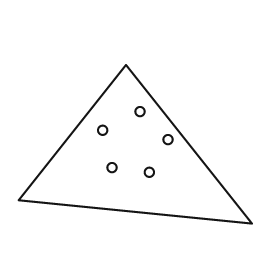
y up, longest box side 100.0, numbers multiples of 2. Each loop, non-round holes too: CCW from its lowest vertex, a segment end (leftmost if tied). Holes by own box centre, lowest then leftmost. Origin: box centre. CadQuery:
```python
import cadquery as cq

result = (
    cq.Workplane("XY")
    .moveTo(50.0, -34.0)
    .lineTo(-4.0, 34.0)
    .lineTo(-50.0, -24.0)
    .close()
    .moveTo(6.0, -12.0)
    .circle(2.0)
    .moveTo(-10.0, -10.0)
    .circle(2.0)
    .moveTo(14.0, 2.0)
    .circle(2.0)
    .moveTo(-14.0, 6.0)
    .circle(2.0)
    .moveTo(2.0, 14.0)
    .circle(2.0)
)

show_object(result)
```